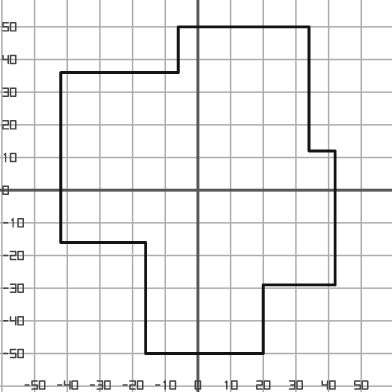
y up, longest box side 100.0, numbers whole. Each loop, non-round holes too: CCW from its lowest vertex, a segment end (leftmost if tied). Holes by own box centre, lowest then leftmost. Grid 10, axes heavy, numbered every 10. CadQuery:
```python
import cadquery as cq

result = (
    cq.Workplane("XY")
    .moveTo(-16.0, -50.0)
    .lineTo(20.0, -50.0)
    .lineTo(20.0, -29.0)
    .lineTo(42.0, -29.0)
    .lineTo(42.0, 12.0)
    .lineTo(34.0, 12.0)
    .lineTo(34.0, 50.0)
    .lineTo(-6.0, 50.0)
    .lineTo(-6.0, 36.0)
    .lineTo(-42.0, 36.0)
    .lineTo(-42.0, -16.0)
    .lineTo(-16.0, -16.0)
    .close()
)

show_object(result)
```